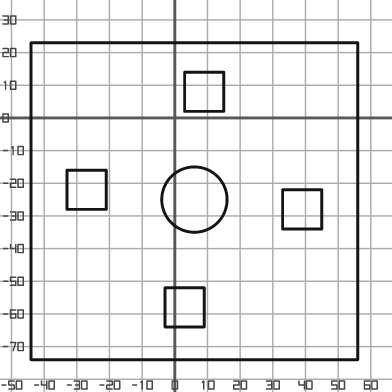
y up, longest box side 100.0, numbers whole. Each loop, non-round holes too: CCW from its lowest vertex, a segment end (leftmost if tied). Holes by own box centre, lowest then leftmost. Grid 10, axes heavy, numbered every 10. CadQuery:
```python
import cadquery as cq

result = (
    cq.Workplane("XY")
    .moveTo(-44.0, -74.0)
    .lineTo(56.0, -74.0)
    .lineTo(56.0, 23.0)
    .lineTo(-44.0, 23.0)
    .close()
    .moveTo(-3.0, -64.0)
    .lineTo(9.0, -64.0)
    .lineTo(9.0, -52.0)
    .lineTo(-3.0, -52.0)
    .close()
    .moveTo(33.0, -34.0)
    .lineTo(45.0, -34.0)
    .lineTo(45.0, -22.0)
    .lineTo(33.0, -22.0)
    .close()
    .moveTo(6.0, -25.0)
    .circle(10.0)
    .moveTo(-33.0, -28.0)
    .lineTo(-21.0, -28.0)
    .lineTo(-21.0, -16.0)
    .lineTo(-33.0, -16.0)
    .close()
    .moveTo(3.0, 2.0)
    .lineTo(15.0, 2.0)
    .lineTo(15.0, 14.0)
    .lineTo(3.0, 14.0)
    .close()
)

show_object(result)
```